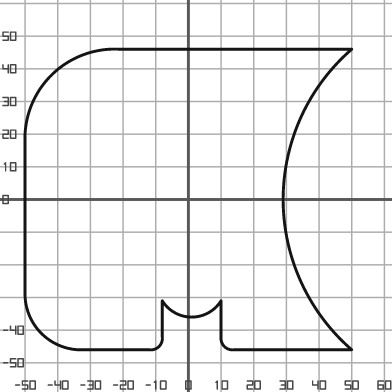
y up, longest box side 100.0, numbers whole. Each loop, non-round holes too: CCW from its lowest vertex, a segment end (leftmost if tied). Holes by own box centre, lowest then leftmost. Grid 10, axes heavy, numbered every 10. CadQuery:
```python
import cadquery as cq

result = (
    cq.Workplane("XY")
    .moveTo(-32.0, -46.0)
    .lineTo(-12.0, -46.0)
    .threePointArc((-9.0, -45.0), (-8.0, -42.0))
    .lineTo(-8.0, -31.0)
    .threePointArc((1.0, -36.0), (10.0, -31.0))
    .lineTo(10.0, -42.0)
    .threePointArc((11.0, -45.0), (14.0, -46.0))
    .lineTo(50.0, -46.0)
    .threePointArc((29.0, 0.0), (50.0, 46.0))
    .lineTo(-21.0, 46.0)
    .threePointArc((-42.0, 38.0), (-50.0, 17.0))
    .lineTo(-50.0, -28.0)
    .threePointArc((-45.0, -41.0), (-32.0, -46.0))
    .close()
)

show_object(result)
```